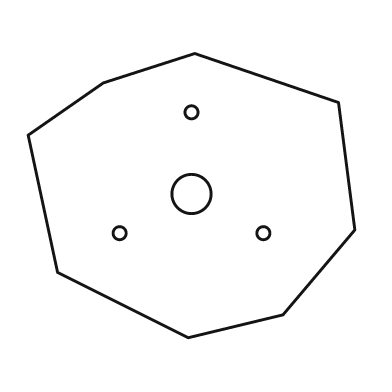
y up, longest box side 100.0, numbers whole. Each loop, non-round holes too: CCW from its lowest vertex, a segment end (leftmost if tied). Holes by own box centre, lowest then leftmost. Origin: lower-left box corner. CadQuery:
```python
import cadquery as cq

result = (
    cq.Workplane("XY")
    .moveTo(49.0, 0.0)
    .lineTo(78.0, 7.0)
    .lineTo(100.0, 33.0)
    .lineTo(95.0, 72.0)
    .lineTo(51.0, 87.0)
    .lineTo(23.0, 78.0)
    .lineTo(0.0, 62.0)
    .lineTo(9.0, 20.0)
    .close()
    .moveTo(28.0, 32.0)
    .circle(2.0)
    .moveTo(72.0, 32.0)
    .circle(2.0)
    .moveTo(50.0, 44.0)
    .circle(6.0)
    .moveTo(50.0, 69.0)
    .circle(2.0)
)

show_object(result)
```